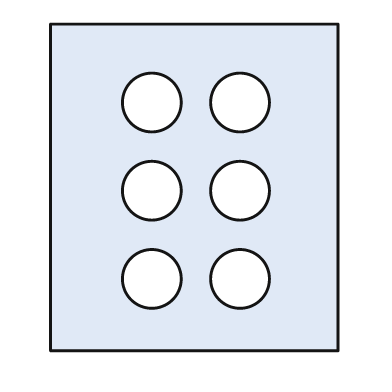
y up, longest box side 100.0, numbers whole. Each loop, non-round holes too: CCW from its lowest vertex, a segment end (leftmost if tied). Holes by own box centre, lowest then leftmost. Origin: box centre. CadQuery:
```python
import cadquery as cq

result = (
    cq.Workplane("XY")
    .moveTo(-44.0, -50.0)
    .lineTo(44.0, -50.0)
    .lineTo(44.0, 50.0)
    .lineTo(-44.0, 50.0)
    .close()
    .moveTo(-13.0, -28.0)
    .circle(9.0)
    .moveTo(14.0, -28.0)
    .circle(9.0)
    .moveTo(-13.0, -1.0)
    .circle(9.0)
    .moveTo(14.0, -1.0)
    .circle(9.0)
    .moveTo(-13.0, 26.0)
    .circle(9.0)
    .moveTo(14.0, 26.0)
    .circle(9.0)
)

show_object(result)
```